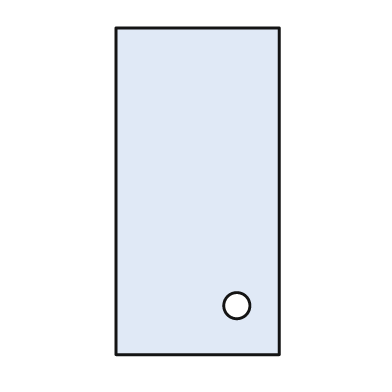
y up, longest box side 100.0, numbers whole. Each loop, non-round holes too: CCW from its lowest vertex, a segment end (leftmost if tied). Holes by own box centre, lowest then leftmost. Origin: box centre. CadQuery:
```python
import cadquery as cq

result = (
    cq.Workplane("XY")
    .moveTo(-25.0, -50.0)
    .lineTo(25.0, -50.0)
    .lineTo(25.0, 50.0)
    .lineTo(-25.0, 50.0)
    .close()
    .moveTo(12.0, -35.0)
    .circle(4.0)
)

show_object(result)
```